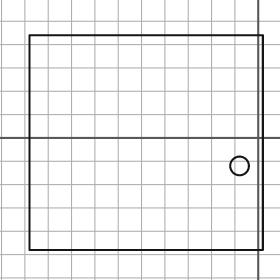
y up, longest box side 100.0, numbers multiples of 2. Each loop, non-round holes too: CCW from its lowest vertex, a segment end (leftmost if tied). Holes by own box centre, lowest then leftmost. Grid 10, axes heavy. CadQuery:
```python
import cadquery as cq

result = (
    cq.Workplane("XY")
    .moveTo(-98.0, -48.0)
    .lineTo(2.0, -48.0)
    .lineTo(2.0, 44.0)
    .lineTo(-98.0, 44.0)
    .close()
    .moveTo(-8.0, -12.0)
    .circle(4.0)
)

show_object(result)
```